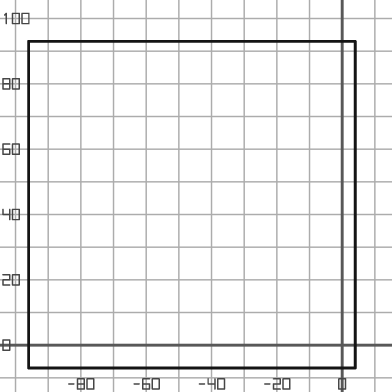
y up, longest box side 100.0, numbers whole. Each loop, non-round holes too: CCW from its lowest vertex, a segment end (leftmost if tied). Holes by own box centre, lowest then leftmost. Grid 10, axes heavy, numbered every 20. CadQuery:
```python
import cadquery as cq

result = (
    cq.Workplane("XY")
    .moveTo(-96.0, -7.0)
    .lineTo(4.0, -7.0)
    .lineTo(4.0, 93.0)
    .lineTo(-96.0, 93.0)
    .close()
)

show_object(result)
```